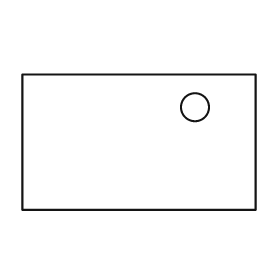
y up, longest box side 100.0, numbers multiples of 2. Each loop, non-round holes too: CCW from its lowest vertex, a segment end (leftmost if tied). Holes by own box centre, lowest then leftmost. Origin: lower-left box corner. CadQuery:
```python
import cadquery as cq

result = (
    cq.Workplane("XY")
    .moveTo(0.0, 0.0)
    .lineTo(100.0, 0.0)
    .lineTo(100.0, 58.0)
    .lineTo(0.0, 58.0)
    .close()
    .moveTo(74.0, 44.0)
    .circle(6.0)
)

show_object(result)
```